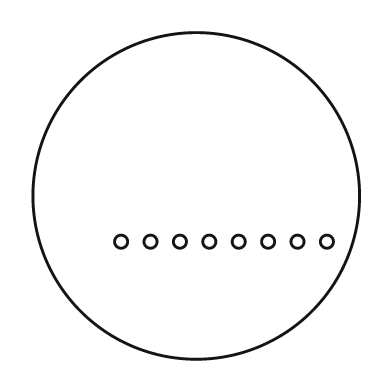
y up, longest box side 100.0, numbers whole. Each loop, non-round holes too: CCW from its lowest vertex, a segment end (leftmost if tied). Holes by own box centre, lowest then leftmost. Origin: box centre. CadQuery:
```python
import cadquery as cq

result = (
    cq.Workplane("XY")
    .moveTo(0.0, 0.0)
    .circle(50.0)
    .moveTo(-23.0, -14.0)
    .circle(2.0)
    .moveTo(-14.0, -14.0)
    .circle(2.0)
    .moveTo(-5.0, -14.0)
    .circle(2.0)
    .moveTo(4.0, -14.0)
    .circle(2.0)
    .moveTo(13.0, -14.0)
    .circle(2.0)
    .moveTo(22.0, -14.0)
    .circle(2.0)
    .moveTo(31.0, -14.0)
    .circle(2.0)
    .moveTo(40.0, -14.0)
    .circle(2.0)
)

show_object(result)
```